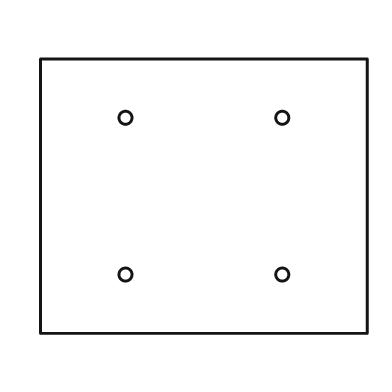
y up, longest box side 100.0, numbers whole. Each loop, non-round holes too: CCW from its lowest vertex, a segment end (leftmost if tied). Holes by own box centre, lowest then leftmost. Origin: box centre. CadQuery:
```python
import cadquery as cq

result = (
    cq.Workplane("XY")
    .moveTo(-50.0, -42.0)
    .lineTo(50.0, -42.0)
    .lineTo(50.0, 42.0)
    .lineTo(-50.0, 42.0)
    .close()
    .moveTo(-24.0, -24.0)
    .circle(2.0)
    .moveTo(24.0, -24.0)
    .circle(2.0)
    .moveTo(-24.0, 24.0)
    .circle(2.0)
    .moveTo(24.0, 24.0)
    .circle(2.0)
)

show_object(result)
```